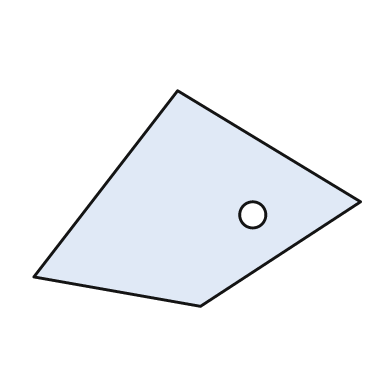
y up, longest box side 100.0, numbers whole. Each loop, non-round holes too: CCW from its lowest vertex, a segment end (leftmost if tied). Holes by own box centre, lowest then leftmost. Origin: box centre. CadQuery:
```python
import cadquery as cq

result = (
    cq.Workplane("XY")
    .moveTo(1.0, -33.0)
    .lineTo(50.0, -1.0)
    .lineTo(-6.0, 33.0)
    .lineTo(-50.0, -24.0)
    .close()
    .moveTo(17.0, -5.0)
    .circle(4.0)
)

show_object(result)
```